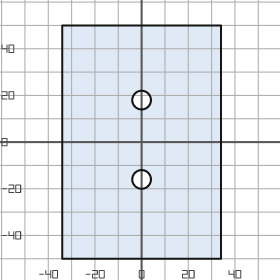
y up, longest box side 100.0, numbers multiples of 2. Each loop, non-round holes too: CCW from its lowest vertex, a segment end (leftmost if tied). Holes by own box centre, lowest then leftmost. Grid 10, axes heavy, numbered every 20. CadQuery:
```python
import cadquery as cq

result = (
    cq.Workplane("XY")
    .moveTo(-34.0, -50.0)
    .lineTo(34.0, -50.0)
    .lineTo(34.0, 50.0)
    .lineTo(-34.0, 50.0)
    .close()
    .moveTo(0.0, -16.0)
    .circle(4.0)
    .moveTo(0.0, 18.0)
    .circle(4.0)
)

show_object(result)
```